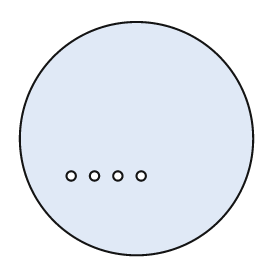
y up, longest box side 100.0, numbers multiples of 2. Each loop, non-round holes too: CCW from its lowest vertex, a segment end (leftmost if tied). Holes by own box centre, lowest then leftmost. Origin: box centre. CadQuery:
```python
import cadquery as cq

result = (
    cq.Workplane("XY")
    .moveTo(0.0, 0.0)
    .circle(50.0)
    .moveTo(-28.0, -16.0)
    .circle(2.0)
    .moveTo(-18.0, -16.0)
    .circle(2.0)
    .moveTo(-8.0, -16.0)
    .circle(2.0)
    .moveTo(2.0, -16.0)
    .circle(2.0)
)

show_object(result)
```